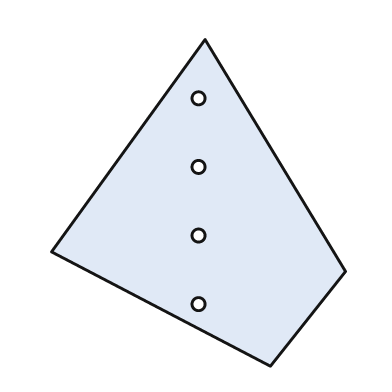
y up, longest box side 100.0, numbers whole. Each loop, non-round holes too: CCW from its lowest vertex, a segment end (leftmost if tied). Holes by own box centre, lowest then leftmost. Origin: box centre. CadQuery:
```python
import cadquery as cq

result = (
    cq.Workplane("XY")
    .moveTo(22.0, -50.0)
    .lineTo(45.0, -21.0)
    .lineTo(2.0, 50.0)
    .lineTo(-45.0, -15.0)
    .close()
    .moveTo(0.0, -31.0)
    .circle(2.0)
    .moveTo(0.0, -10.0)
    .circle(2.0)
    .moveTo(0.0, 11.0)
    .circle(2.0)
    .moveTo(0.0, 32.0)
    .circle(2.0)
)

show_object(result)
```